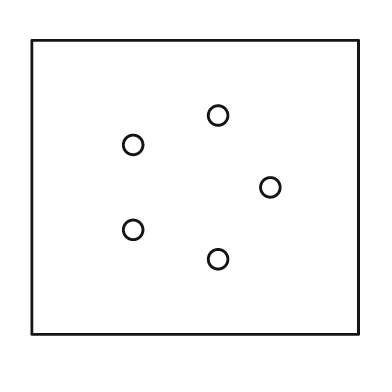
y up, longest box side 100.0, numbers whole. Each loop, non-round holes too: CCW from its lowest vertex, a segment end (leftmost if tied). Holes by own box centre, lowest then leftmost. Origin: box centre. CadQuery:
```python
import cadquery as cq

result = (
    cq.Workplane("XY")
    .moveTo(-50.0, -45.0)
    .lineTo(50.0, -45.0)
    .lineTo(50.0, 45.0)
    .lineTo(-50.0, 45.0)
    .close()
    .moveTo(7.0, -22.0)
    .circle(3.0)
    .moveTo(-19.0, -13.0)
    .circle(3.0)
    .moveTo(23.0, 0.0)
    .circle(3.0)
    .moveTo(-19.0, 13.0)
    .circle(3.0)
    .moveTo(7.0, 22.0)
    .circle(3.0)
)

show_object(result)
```